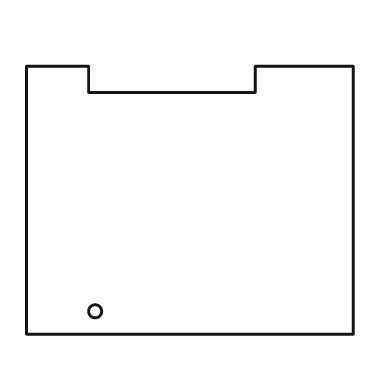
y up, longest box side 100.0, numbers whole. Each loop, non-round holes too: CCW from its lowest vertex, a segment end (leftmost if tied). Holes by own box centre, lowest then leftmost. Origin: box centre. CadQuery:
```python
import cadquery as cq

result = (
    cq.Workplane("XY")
    .moveTo(-50.0, -41.0)
    .lineTo(50.0, -41.0)
    .lineTo(50.0, 41.0)
    .lineTo(20.0, 41.0)
    .lineTo(20.0, 33.0)
    .lineTo(-31.0, 33.0)
    .lineTo(-31.0, 41.0)
    .lineTo(-50.0, 41.0)
    .close()
    .moveTo(-29.0, -34.0)
    .circle(2.0)
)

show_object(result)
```